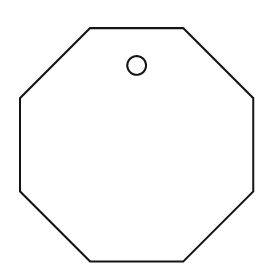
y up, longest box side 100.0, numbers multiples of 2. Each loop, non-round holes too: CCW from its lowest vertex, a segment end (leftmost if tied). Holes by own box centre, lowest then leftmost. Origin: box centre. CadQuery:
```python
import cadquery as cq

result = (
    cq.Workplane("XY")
    .moveTo(-20.0, -50.0)
    .lineTo(20.0, -50.0)
    .lineTo(50.0, -20.0)
    .lineTo(50.0, 20.0)
    .lineTo(20.0, 50.0)
    .lineTo(-20.0, 50.0)
    .lineTo(-50.0, 20.0)
    .lineTo(-50.0, -20.0)
    .close()
    .moveTo(0.0, 34.0)
    .circle(4.0)
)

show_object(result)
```